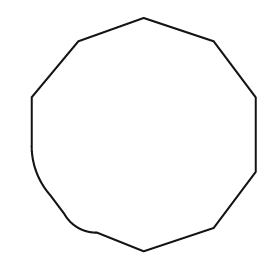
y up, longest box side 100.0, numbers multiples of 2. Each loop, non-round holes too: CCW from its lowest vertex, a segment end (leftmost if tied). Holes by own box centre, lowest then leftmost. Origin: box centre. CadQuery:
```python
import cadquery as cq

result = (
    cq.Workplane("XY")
    .moveTo(0.0, -50.0)
    .lineTo(30.0, -40.0)
    .lineTo(48.0, -16.0)
    .lineTo(48.0, 16.0)
    .lineTo(30.0, 40.0)
    .lineTo(0.0, 50.0)
    .lineTo(-28.0, 40.0)
    .lineTo(-48.0, 16.0)
    .lineTo(-48.0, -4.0)
    .threePointArc((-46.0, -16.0), (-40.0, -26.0))
    .lineTo(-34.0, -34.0)
    .threePointArc((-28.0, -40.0), (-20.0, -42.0))
    .close()
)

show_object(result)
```